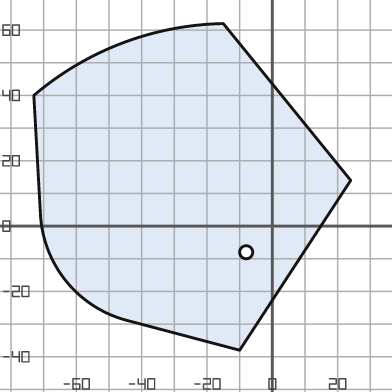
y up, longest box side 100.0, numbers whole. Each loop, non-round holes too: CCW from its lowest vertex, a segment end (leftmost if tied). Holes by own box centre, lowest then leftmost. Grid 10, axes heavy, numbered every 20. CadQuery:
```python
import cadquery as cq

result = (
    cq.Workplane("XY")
    .moveTo(-10.0, -38.0)
    .lineTo(24.0, 14.0)
    .lineTo(-15.0, 62.0)
    .threePointArc((-46.0, 56.0), (-73.0, 40.0))
    .lineTo(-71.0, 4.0)
    .threePointArc((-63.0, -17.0), (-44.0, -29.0))
    .close()
    .moveTo(-8.0, -8.0)
    .circle(2.0)
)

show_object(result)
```